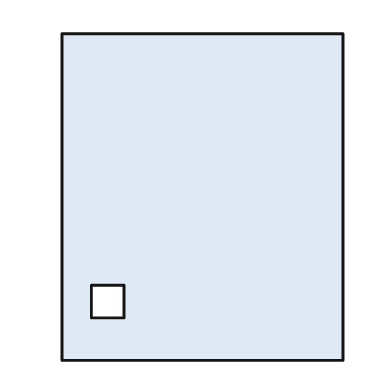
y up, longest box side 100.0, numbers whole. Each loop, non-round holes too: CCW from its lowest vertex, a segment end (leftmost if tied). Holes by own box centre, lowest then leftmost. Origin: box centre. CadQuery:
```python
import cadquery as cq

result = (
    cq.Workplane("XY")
    .moveTo(-43.0, -50.0)
    .lineTo(43.0, -50.0)
    .lineTo(43.0, 50.0)
    .lineTo(-43.0, 50.0)
    .close()
    .moveTo(-34.0, -37.0)
    .lineTo(-24.0, -37.0)
    .lineTo(-24.0, -27.0)
    .lineTo(-34.0, -27.0)
    .close()
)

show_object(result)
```